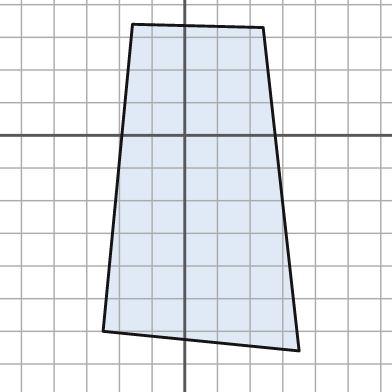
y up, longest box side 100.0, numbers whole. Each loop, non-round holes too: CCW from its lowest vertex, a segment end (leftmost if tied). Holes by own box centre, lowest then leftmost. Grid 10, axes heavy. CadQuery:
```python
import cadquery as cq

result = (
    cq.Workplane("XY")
    .moveTo(35.0, -66.0)
    .lineTo(24.0, 33.0)
    .lineTo(-16.0, 34.0)
    .lineTo(-25.0, -60.0)
    .close()
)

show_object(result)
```